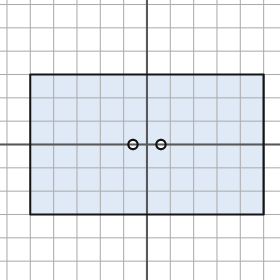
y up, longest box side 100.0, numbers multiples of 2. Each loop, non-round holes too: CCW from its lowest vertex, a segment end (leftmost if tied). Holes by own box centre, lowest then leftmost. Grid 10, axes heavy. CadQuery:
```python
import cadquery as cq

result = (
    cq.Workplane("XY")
    .moveTo(-50.0, -30.0)
    .lineTo(50.0, -30.0)
    .lineTo(50.0, 30.0)
    .lineTo(-50.0, 30.0)
    .close()
    .moveTo(-6.0, 0.0)
    .circle(2.0)
    .moveTo(6.0, 0.0)
    .circle(2.0)
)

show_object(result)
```